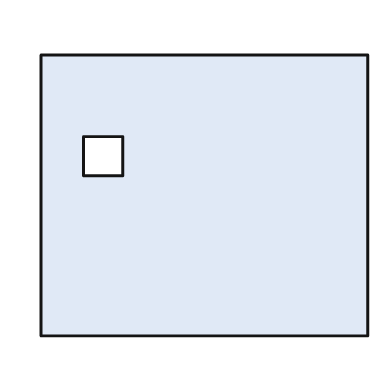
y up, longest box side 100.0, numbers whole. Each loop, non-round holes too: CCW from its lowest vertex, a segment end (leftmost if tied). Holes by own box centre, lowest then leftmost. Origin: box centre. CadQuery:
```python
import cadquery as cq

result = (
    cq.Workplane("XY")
    .moveTo(-50.0, -43.0)
    .lineTo(50.0, -43.0)
    .lineTo(50.0, 43.0)
    .lineTo(-50.0, 43.0)
    .close()
    .moveTo(-37.0, 6.0)
    .lineTo(-25.0, 6.0)
    .lineTo(-25.0, 18.0)
    .lineTo(-37.0, 18.0)
    .close()
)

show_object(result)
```